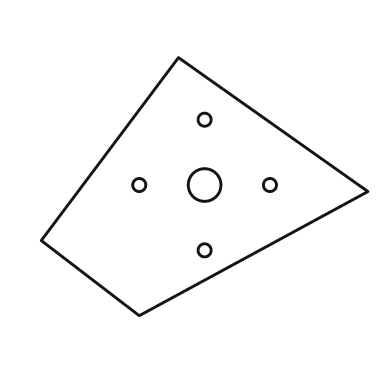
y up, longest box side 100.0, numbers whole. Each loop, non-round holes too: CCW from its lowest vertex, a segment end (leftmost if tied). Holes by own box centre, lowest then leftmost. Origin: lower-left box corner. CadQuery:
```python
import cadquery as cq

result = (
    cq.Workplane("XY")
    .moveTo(30.0, 0.0)
    .lineTo(100.0, 38.0)
    .lineTo(42.0, 79.0)
    .lineTo(0.0, 23.0)
    .close()
    .moveTo(50.0, 20.0)
    .circle(2.0)
    .moveTo(30.0, 40.0)
    .circle(2.0)
    .moveTo(50.0, 40.0)
    .circle(5.0)
    .moveTo(70.0, 40.0)
    .circle(2.0)
    .moveTo(50.0, 60.0)
    .circle(2.0)
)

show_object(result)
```